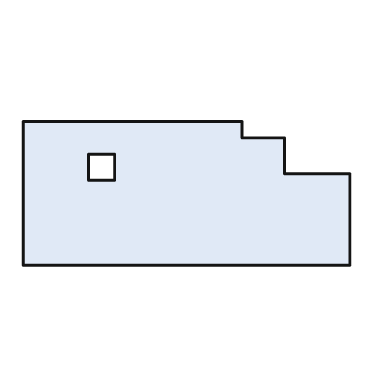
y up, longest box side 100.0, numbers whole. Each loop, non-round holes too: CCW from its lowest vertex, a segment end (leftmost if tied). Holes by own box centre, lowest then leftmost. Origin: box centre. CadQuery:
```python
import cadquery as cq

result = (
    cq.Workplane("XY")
    .moveTo(-50.0, -22.0)
    .lineTo(50.0, -22.0)
    .lineTo(50.0, 6.0)
    .lineTo(30.0, 6.0)
    .lineTo(30.0, 17.0)
    .lineTo(17.0, 17.0)
    .lineTo(17.0, 22.0)
    .lineTo(-50.0, 22.0)
    .close()
    .moveTo(-30.0, 4.0)
    .lineTo(-22.0, 4.0)
    .lineTo(-22.0, 12.0)
    .lineTo(-30.0, 12.0)
    .close()
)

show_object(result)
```